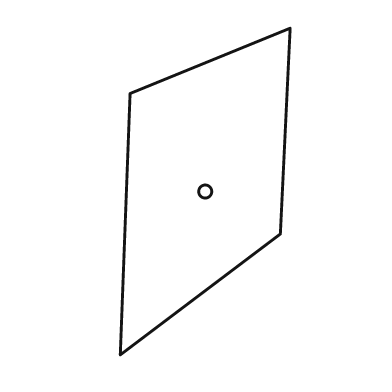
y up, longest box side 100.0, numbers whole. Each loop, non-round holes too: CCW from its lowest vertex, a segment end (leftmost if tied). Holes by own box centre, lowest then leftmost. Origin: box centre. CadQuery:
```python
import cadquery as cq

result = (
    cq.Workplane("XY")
    .moveTo(-26.0, -50.0)
    .lineTo(23.0, -13.0)
    .lineTo(26.0, 50.0)
    .lineTo(-23.0, 30.0)
    .close()
    .moveTo(0.0, 0.0)
    .circle(2.0)
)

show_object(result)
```